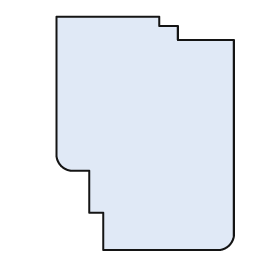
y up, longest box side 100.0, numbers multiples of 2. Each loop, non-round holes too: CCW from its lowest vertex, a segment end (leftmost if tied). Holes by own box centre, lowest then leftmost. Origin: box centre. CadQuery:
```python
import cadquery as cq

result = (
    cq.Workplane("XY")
    .moveTo(-18.0, -50.0)
    .lineTo(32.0, -50.0)
    .threePointArc((36.0, -48.0), (38.0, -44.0))
    .lineTo(38.0, 40.0)
    .lineTo(14.0, 40.0)
    .lineTo(14.0, 46.0)
    .lineTo(6.0, 46.0)
    .lineTo(6.0, 50.0)
    .lineTo(-38.0, 50.0)
    .lineTo(-38.0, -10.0)
    .threePointArc((-36.0, -14.0), (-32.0, -16.0))
    .lineTo(-24.0, -16.0)
    .lineTo(-24.0, -34.0)
    .lineTo(-18.0, -34.0)
    .close()
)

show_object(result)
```